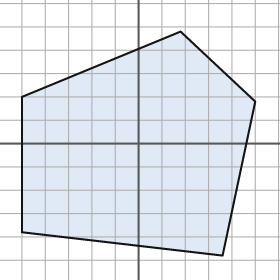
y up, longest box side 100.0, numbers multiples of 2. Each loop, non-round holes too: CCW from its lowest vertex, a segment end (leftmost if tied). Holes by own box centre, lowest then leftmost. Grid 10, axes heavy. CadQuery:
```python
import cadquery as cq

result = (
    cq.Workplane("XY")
    .moveTo(36.0, -48.0)
    .lineTo(50.0, 18.0)
    .lineTo(18.0, 48.0)
    .lineTo(-50.0, 20.0)
    .lineTo(-50.0, -38.0)
    .close()
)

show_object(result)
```